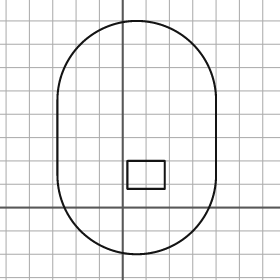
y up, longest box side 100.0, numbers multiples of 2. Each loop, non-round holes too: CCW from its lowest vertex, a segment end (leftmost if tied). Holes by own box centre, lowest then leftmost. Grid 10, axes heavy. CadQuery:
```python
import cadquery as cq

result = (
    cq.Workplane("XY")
    .moveTo(-28.0, 14.0)
    .threePointArc((6.0, -20.0), (40.0, 14.0))
    .lineTo(40.0, 46.0)
    .threePointArc((6.0, 80.0), (-28.0, 46.0))
    .close()
    .moveTo(2.0, 8.0)
    .lineTo(18.0, 8.0)
    .lineTo(18.0, 20.0)
    .lineTo(2.0, 20.0)
    .close()
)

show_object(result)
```